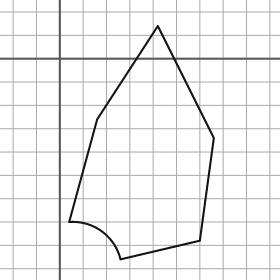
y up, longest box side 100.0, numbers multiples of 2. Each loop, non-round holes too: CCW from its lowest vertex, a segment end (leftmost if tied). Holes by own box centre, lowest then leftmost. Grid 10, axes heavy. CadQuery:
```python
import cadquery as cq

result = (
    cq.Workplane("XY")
    .moveTo(26.0, -86.0)
    .lineTo(60.0, -78.0)
    .lineTo(66.0, -34.0)
    .lineTo(42.0, 14.0)
    .lineTo(16.0, -26.0)
    .lineTo(4.0, -70.0)
    .threePointArc((18.0, -74.0), (26.0, -86.0))
    .close()
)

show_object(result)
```